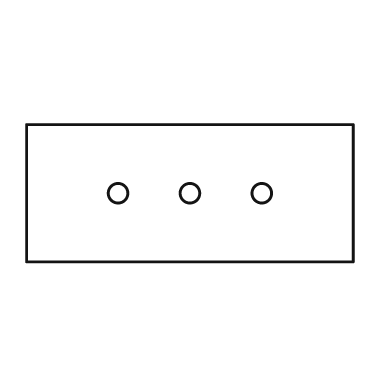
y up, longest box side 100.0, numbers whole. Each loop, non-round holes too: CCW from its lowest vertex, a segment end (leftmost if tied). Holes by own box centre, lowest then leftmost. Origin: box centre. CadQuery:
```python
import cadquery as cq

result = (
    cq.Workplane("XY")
    .moveTo(-50.0, -21.0)
    .lineTo(50.0, -21.0)
    .lineTo(50.0, 21.0)
    .lineTo(-50.0, 21.0)
    .close()
    .moveTo(-22.0, 0.0)
    .circle(3.0)
    .moveTo(0.0, 0.0)
    .circle(3.0)
    .moveTo(22.0, 0.0)
    .circle(3.0)
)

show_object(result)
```